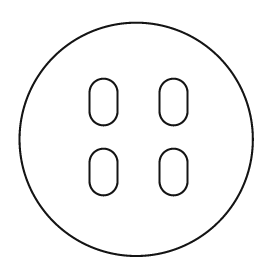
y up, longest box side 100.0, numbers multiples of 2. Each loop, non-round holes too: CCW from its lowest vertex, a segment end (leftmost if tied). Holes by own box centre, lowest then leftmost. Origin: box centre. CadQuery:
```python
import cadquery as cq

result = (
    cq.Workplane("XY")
    .moveTo(0.0, 0.0)
    .circle(50.0)
    .moveTo(-20.0, -18.0)
    .threePointArc((-14.0, -24.0), (-8.0, -18.0))
    .lineTo(-8.0, -10.0)
    .threePointArc((-14.0, -4.0), (-20.0, -10.0))
    .close()
    .moveTo(10.0, -18.0)
    .threePointArc((16.0, -24.0), (22.0, -18.0))
    .lineTo(22.0, -10.0)
    .threePointArc((16.0, -4.0), (10.0, -10.0))
    .close()
    .moveTo(-20.0, 12.0)
    .threePointArc((-14.0, 6.0), (-8.0, 12.0))
    .lineTo(-8.0, 20.0)
    .threePointArc((-14.0, 26.0), (-20.0, 20.0))
    .close()
    .moveTo(10.0, 12.0)
    .threePointArc((16.0, 6.0), (22.0, 12.0))
    .lineTo(22.0, 20.0)
    .threePointArc((16.0, 26.0), (10.0, 20.0))
    .close()
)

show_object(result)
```